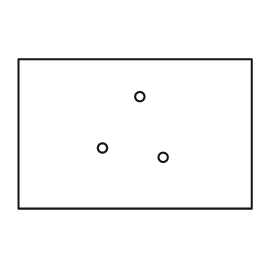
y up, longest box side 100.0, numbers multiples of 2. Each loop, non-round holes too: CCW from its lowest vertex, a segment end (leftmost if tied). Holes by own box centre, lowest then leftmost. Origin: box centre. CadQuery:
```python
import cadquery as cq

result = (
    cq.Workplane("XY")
    .moveTo(-50.0, -32.0)
    .lineTo(50.0, -32.0)
    .lineTo(50.0, 32.0)
    .lineTo(-50.0, 32.0)
    .close()
    .moveTo(12.0, -10.0)
    .circle(2.0)
    .moveTo(-14.0, -6.0)
    .circle(2.0)
    .moveTo(2.0, 16.0)
    .circle(2.0)
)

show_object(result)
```